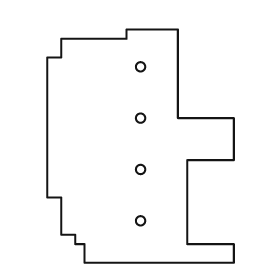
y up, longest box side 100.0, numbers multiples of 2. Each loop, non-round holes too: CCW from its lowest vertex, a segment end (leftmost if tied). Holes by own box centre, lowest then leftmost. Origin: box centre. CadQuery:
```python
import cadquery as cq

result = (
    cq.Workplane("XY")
    .moveTo(-24.0, -50.0)
    .lineTo(40.0, -50.0)
    .lineTo(40.0, -42.0)
    .lineTo(20.0, -42.0)
    .lineTo(20.0, -6.0)
    .lineTo(40.0, -6.0)
    .lineTo(40.0, 12.0)
    .lineTo(16.0, 12.0)
    .lineTo(16.0, 50.0)
    .lineTo(-6.0, 50.0)
    .lineTo(-6.0, 46.0)
    .lineTo(-34.0, 46.0)
    .lineTo(-34.0, 38.0)
    .lineTo(-40.0, 38.0)
    .lineTo(-40.0, -22.0)
    .lineTo(-34.0, -22.0)
    .lineTo(-34.0, -38.0)
    .lineTo(-28.0, -38.0)
    .lineTo(-28.0, -42.0)
    .lineTo(-24.0, -42.0)
    .close()
    .moveTo(0.0, -32.0)
    .circle(2.0)
    .moveTo(0.0, -10.0)
    .circle(2.0)
    .moveTo(0.0, 12.0)
    .circle(2.0)
    .moveTo(0.0, 34.0)
    .circle(2.0)
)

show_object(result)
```